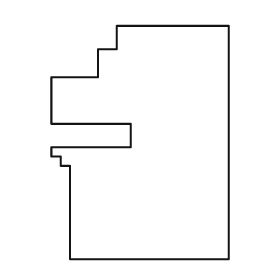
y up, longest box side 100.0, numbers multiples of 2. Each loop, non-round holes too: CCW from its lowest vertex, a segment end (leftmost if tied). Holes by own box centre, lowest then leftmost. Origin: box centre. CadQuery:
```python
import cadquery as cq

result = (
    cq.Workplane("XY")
    .moveTo(-30.0, -50.0)
    .lineTo(38.0, -50.0)
    .lineTo(38.0, 50.0)
    .lineTo(-10.0, 50.0)
    .lineTo(-10.0, 40.0)
    .lineTo(-18.0, 40.0)
    .lineTo(-18.0, 28.0)
    .lineTo(-38.0, 28.0)
    .lineTo(-38.0, 8.0)
    .lineTo(-4.0, 8.0)
    .lineTo(-4.0, -2.0)
    .lineTo(-38.0, -2.0)
    .lineTo(-38.0, -6.0)
    .lineTo(-34.0, -6.0)
    .lineTo(-34.0, -10.0)
    .lineTo(-30.0, -10.0)
    .close()
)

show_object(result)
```